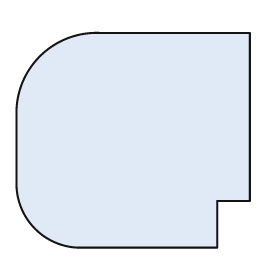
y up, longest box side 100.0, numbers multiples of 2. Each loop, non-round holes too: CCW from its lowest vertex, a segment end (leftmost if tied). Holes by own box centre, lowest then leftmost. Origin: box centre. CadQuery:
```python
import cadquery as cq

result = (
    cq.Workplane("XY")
    .moveTo(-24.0, -46.0)
    .lineTo(36.0, -46.0)
    .lineTo(36.0, -26.0)
    .lineTo(50.0, -26.0)
    .lineTo(50.0, 46.0)
    .lineTo(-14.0, 46.0)
    .threePointArc((-40.0, 36.0), (-50.0, 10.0))
    .lineTo(-50.0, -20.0)
    .threePointArc((-42.0, -38.0), (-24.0, -46.0))
    .close()
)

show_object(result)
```